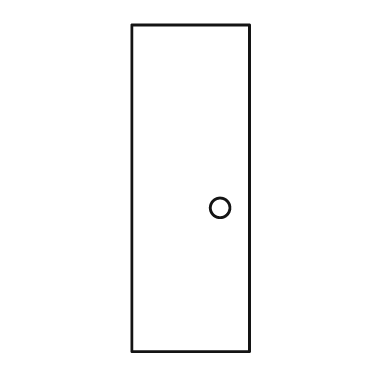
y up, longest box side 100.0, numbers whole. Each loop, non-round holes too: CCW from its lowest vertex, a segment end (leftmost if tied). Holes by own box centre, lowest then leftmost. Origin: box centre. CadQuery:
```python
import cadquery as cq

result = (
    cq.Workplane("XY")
    .moveTo(-18.0, -50.0)
    .lineTo(18.0, -50.0)
    .lineTo(18.0, 50.0)
    .lineTo(-18.0, 50.0)
    .close()
    .moveTo(9.0, -6.0)
    .circle(3.0)
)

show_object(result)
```